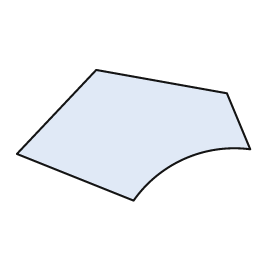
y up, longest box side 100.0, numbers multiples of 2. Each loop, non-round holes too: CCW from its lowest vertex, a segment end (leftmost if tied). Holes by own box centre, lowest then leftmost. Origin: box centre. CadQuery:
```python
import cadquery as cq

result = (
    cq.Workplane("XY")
    .moveTo(0.0, -28.0)
    .threePointArc((22.0, -10.0), (50.0, -6.0))
    .lineTo(40.0, 18.0)
    .lineTo(-16.0, 28.0)
    .lineTo(-50.0, -8.0)
    .close()
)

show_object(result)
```